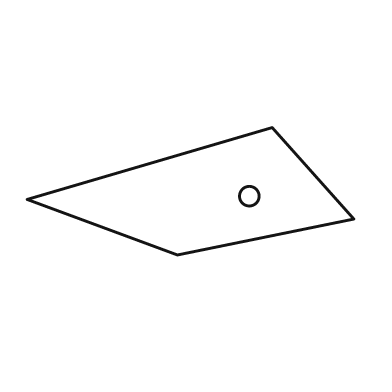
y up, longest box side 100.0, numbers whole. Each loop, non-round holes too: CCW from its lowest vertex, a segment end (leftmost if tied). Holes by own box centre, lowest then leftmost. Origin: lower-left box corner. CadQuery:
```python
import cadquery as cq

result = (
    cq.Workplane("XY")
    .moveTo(46.0, 0.0)
    .lineTo(100.0, 11.0)
    .lineTo(75.0, 39.0)
    .lineTo(0.0, 17.0)
    .close()
    .moveTo(68.0, 18.0)
    .circle(3.0)
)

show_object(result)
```